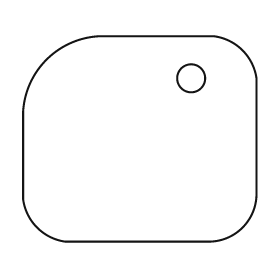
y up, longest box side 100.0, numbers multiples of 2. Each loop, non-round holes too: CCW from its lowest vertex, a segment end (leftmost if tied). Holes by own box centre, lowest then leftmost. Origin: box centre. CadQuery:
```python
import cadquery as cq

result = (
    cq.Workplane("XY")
    .moveTo(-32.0, -44.0)
    .lineTo(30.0, -44.0)
    .threePointArc((44.0, -38.0), (50.0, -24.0))
    .lineTo(50.0, 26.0)
    .threePointArc((44.0, 38.0), (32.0, 44.0))
    .lineTo(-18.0, 44.0)
    .threePointArc((-40.0, 34.0), (-50.0, 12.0))
    .lineTo(-50.0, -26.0)
    .threePointArc((-44.0, -38.0), (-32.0, -44.0))
    .close()
    .moveTo(22.0, 26.0)
    .circle(6.0)
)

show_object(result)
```